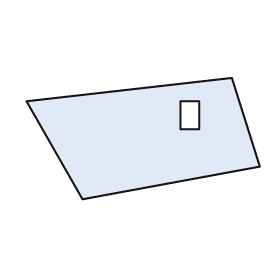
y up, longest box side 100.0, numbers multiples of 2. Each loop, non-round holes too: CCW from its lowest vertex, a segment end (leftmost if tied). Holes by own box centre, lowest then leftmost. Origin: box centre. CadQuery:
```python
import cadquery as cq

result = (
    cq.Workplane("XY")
    .moveTo(-26.0, -26.0)
    .lineTo(50.0, -12.0)
    .lineTo(38.0, 26.0)
    .lineTo(-50.0, 16.0)
    .close()
    .moveTo(16.0, 4.0)
    .lineTo(24.0, 4.0)
    .lineTo(24.0, 16.0)
    .lineTo(16.0, 16.0)
    .close()
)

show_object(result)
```